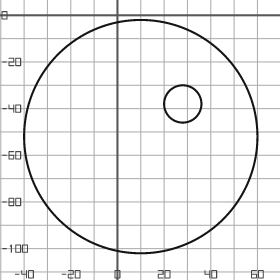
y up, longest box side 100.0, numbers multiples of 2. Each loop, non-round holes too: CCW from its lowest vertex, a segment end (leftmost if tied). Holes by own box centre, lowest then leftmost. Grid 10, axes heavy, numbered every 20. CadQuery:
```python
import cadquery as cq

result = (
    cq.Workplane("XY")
    .moveTo(10.0, -52.0)
    .circle(50.0)
    .moveTo(28.0, -38.0)
    .circle(8.0)
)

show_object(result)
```